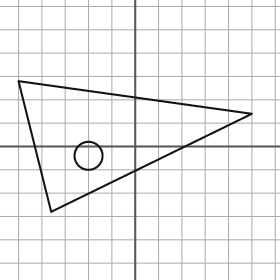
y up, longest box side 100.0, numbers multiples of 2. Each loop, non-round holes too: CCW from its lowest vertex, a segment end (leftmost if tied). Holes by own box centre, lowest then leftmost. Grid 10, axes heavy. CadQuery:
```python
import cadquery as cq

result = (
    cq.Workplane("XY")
    .moveTo(-36.0, -28.0)
    .lineTo(50.0, 14.0)
    .lineTo(-50.0, 28.0)
    .close()
    .moveTo(-20.0, -4.0)
    .circle(6.0)
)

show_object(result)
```